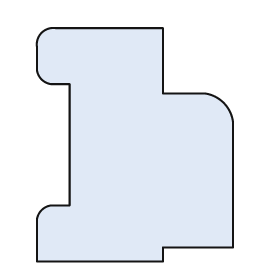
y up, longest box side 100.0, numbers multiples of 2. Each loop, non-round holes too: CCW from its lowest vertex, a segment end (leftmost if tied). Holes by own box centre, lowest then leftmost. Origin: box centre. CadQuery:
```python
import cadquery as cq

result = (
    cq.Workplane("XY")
    .moveTo(-42.0, -50.0)
    .lineTo(12.0, -50.0)
    .lineTo(12.0, -44.0)
    .lineTo(42.0, -44.0)
    .lineTo(42.0, 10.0)
    .threePointArc((38.0, 18.0), (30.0, 22.0))
    .lineTo(12.0, 22.0)
    .lineTo(12.0, 50.0)
    .lineTo(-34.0, 50.0)
    .threePointArc((-40.0, 48.0), (-42.0, 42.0))
    .lineTo(-42.0, 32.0)
    .threePointArc((-40.0, 28.0), (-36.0, 26.0))
    .lineTo(-28.0, 26.0)
    .lineTo(-28.0, -26.0)
    .lineTo(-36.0, -26.0)
    .threePointArc((-40.0, -28.0), (-42.0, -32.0))
    .close()
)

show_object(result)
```